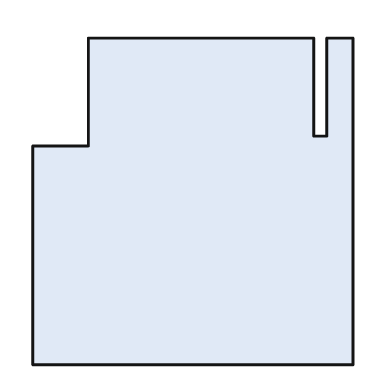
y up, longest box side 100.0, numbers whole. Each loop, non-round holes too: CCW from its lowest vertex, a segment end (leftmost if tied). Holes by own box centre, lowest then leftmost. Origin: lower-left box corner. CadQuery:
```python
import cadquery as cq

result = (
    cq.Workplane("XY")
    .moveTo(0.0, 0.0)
    .lineTo(98.0, 0.0)
    .lineTo(98.0, 100.0)
    .lineTo(90.0, 100.0)
    .lineTo(90.0, 70.0)
    .lineTo(86.0, 70.0)
    .lineTo(86.0, 100.0)
    .lineTo(17.0, 100.0)
    .lineTo(17.0, 67.0)
    .lineTo(0.0, 67.0)
    .close()
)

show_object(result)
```